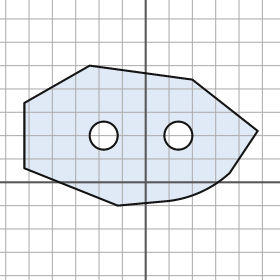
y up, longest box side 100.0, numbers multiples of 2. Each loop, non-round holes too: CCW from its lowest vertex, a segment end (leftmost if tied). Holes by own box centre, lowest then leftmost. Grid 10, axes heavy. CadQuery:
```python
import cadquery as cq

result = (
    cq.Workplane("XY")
    .moveTo(-12.0, -10.0)
    .lineTo(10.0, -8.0)
    .threePointArc((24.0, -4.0), (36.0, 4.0))
    .lineTo(48.0, 22.0)
    .lineTo(20.0, 44.0)
    .lineTo(-24.0, 50.0)
    .lineTo(-52.0, 34.0)
    .lineTo(-52.0, 6.0)
    .close()
    .moveTo(-18.0, 20.0)
    .circle(6.0)
    .moveTo(14.0, 20.0)
    .circle(6.0)
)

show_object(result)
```